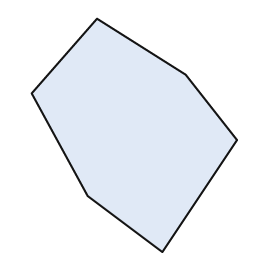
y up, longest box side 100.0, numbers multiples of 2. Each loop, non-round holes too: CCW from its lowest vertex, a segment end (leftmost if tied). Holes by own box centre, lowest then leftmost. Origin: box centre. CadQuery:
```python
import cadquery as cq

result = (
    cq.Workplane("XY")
    .moveTo(12.0, -50.0)
    .lineTo(44.0, -2.0)
    .lineTo(22.0, 26.0)
    .lineTo(-16.0, 50.0)
    .lineTo(-44.0, 18.0)
    .lineTo(-20.0, -26.0)
    .close()
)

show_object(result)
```